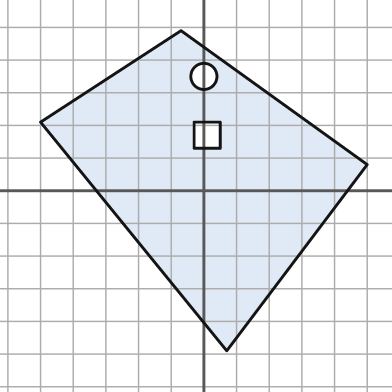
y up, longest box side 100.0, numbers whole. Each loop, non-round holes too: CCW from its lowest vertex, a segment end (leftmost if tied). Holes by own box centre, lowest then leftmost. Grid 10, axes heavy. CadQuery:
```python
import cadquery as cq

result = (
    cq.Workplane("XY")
    .moveTo(7.0, -49.0)
    .lineTo(50.0, 8.0)
    .lineTo(-7.0, 49.0)
    .lineTo(-50.0, 21.0)
    .close()
    .moveTo(-3.0, 13.0)
    .lineTo(5.0, 13.0)
    .lineTo(5.0, 21.0)
    .lineTo(-3.0, 21.0)
    .close()
    .moveTo(0.0, 35.0)
    .circle(4.0)
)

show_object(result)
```